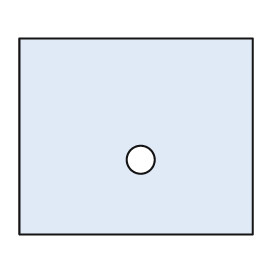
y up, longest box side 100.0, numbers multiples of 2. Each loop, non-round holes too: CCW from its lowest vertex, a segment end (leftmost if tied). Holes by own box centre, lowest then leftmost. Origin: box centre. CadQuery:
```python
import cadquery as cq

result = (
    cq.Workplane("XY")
    .moveTo(-50.0, -42.0)
    .lineTo(50.0, -42.0)
    .lineTo(50.0, 42.0)
    .lineTo(-50.0, 42.0)
    .close()
    .moveTo(2.0, -10.0)
    .circle(6.0)
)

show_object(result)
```